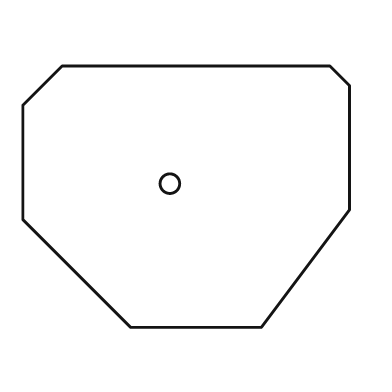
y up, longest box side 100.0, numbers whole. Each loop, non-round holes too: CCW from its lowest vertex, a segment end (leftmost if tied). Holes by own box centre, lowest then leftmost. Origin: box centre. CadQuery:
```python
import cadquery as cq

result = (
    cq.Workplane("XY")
    .moveTo(-17.0, -40.0)
    .lineTo(23.0, -40.0)
    .lineTo(50.0, -4.0)
    .lineTo(50.0, 34.0)
    .lineTo(44.0, 40.0)
    .lineTo(-38.0, 40.0)
    .lineTo(-50.0, 28.0)
    .lineTo(-50.0, -7.0)
    .close()
    .moveTo(-5.0, 4.0)
    .circle(3.0)
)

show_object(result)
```